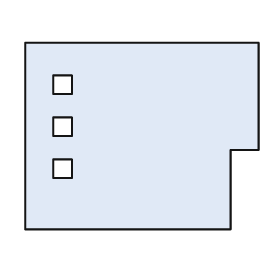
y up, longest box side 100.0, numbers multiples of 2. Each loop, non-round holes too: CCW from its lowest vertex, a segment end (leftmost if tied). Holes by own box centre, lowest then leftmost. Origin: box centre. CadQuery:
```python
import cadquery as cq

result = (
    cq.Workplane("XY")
    .moveTo(-50.0, -40.0)
    .lineTo(38.0, -40.0)
    .lineTo(38.0, -6.0)
    .lineTo(50.0, -6.0)
    .lineTo(50.0, 40.0)
    .lineTo(-50.0, 40.0)
    .close()
    .moveTo(-38.0, -18.0)
    .lineTo(-30.0, -18.0)
    .lineTo(-30.0, -10.0)
    .lineTo(-38.0, -10.0)
    .close()
    .moveTo(-38.0, 0.0)
    .lineTo(-30.0, 0.0)
    .lineTo(-30.0, 8.0)
    .lineTo(-38.0, 8.0)
    .close()
    .moveTo(-38.0, 18.0)
    .lineTo(-30.0, 18.0)
    .lineTo(-30.0, 26.0)
    .lineTo(-38.0, 26.0)
    .close()
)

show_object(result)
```